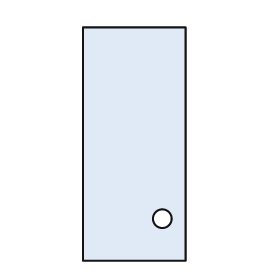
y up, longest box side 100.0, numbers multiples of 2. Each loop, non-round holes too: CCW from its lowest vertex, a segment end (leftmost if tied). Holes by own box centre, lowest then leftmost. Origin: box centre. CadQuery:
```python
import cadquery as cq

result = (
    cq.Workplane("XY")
    .moveTo(-22.0, -50.0)
    .lineTo(22.0, -50.0)
    .lineTo(22.0, 50.0)
    .lineTo(-22.0, 50.0)
    .close()
    .moveTo(12.0, -32.0)
    .circle(4.0)
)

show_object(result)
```